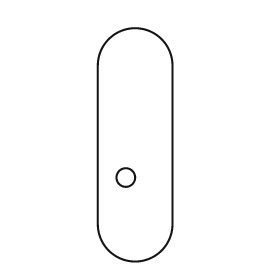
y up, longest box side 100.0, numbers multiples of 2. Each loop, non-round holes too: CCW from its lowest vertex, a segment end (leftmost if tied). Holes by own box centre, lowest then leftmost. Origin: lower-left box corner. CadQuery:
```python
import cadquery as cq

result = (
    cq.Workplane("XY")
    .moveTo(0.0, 16.0)
    .threePointArc((16.0, 0.0), (32.0, 16.0))
    .lineTo(32.0, 84.0)
    .threePointArc((16.0, 100.0), (0.0, 84.0))
    .close()
    .moveTo(12.0, 36.0)
    .circle(4.0)
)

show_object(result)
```